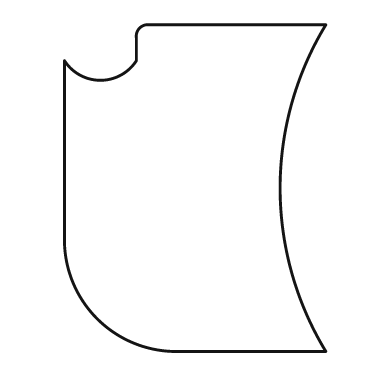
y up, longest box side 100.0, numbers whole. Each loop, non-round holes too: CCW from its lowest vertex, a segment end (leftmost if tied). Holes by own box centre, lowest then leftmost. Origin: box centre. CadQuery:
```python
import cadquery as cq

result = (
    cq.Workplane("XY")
    .moveTo(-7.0, -50.0)
    .lineTo(40.0, -50.0)
    .threePointArc((26.0, 0.0), (40.0, 50.0))
    .lineTo(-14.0, 50.0)
    .threePointArc((-17.0, 49.0), (-18.0, 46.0))
    .lineTo(-18.0, 39.0)
    .threePointArc((-29.0, 33.0), (-40.0, 39.0))
    .lineTo(-40.0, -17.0)
    .threePointArc((-30.0, -40.0), (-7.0, -50.0))
    .close()
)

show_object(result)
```